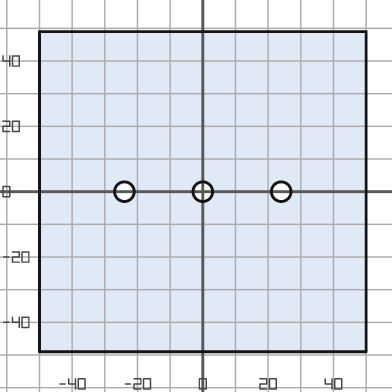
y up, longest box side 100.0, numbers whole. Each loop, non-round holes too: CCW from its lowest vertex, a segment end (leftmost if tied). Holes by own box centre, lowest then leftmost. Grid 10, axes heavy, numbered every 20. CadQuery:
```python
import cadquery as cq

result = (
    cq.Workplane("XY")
    .moveTo(-50.0, -49.0)
    .lineTo(50.0, -49.0)
    .lineTo(50.0, 49.0)
    .lineTo(-50.0, 49.0)
    .close()
    .moveTo(-24.0, 0.0)
    .circle(3.0)
    .moveTo(0.0, 0.0)
    .circle(3.0)
    .moveTo(24.0, 0.0)
    .circle(3.0)
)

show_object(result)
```